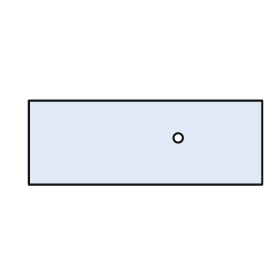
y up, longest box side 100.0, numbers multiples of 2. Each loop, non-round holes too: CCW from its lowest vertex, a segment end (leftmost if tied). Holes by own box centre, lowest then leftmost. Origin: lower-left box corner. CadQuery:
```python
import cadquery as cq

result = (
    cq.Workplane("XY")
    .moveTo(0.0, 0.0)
    .lineTo(100.0, 0.0)
    .lineTo(100.0, 36.0)
    .lineTo(0.0, 36.0)
    .close()
    .moveTo(64.0, 20.0)
    .circle(2.0)
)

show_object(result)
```